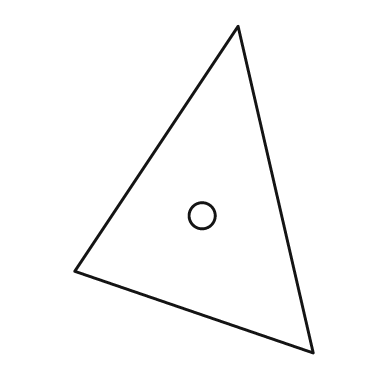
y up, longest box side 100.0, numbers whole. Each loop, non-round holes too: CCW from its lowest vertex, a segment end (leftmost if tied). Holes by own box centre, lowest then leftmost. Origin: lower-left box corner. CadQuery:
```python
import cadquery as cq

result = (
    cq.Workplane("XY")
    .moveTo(73.0, 0.0)
    .lineTo(50.0, 100.0)
    .lineTo(0.0, 25.0)
    .close()
    .moveTo(39.0, 42.0)
    .circle(4.0)
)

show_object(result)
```